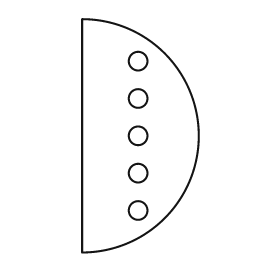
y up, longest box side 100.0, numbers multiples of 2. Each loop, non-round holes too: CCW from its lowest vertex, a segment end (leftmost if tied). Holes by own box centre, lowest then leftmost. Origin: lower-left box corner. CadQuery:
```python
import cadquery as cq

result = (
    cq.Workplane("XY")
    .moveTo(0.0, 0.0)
    .threePointArc((50.0, 50.0), (0.0, 100.0))
    .close()
    .moveTo(24.0, 18.0)
    .circle(4.0)
    .moveTo(24.0, 34.0)
    .circle(4.0)
    .moveTo(24.0, 50.0)
    .circle(4.0)
    .moveTo(24.0, 66.0)
    .circle(4.0)
    .moveTo(24.0, 82.0)
    .circle(4.0)
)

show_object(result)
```